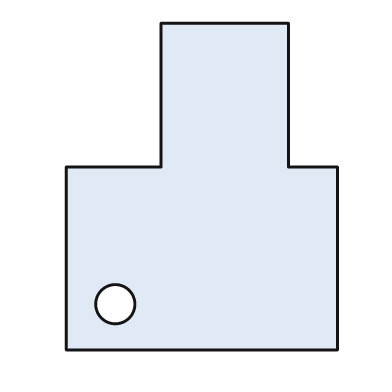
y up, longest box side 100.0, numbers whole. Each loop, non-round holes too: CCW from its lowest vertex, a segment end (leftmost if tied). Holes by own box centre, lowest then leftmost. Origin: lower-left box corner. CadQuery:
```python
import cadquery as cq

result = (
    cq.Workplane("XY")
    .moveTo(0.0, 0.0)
    .lineTo(83.0, 0.0)
    .lineTo(83.0, 56.0)
    .lineTo(68.0, 56.0)
    .lineTo(68.0, 100.0)
    .lineTo(29.0, 100.0)
    .lineTo(29.0, 56.0)
    .lineTo(0.0, 56.0)
    .close()
    .moveTo(15.0, 14.0)
    .circle(6.0)
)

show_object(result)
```